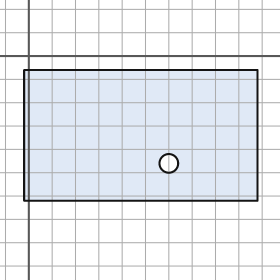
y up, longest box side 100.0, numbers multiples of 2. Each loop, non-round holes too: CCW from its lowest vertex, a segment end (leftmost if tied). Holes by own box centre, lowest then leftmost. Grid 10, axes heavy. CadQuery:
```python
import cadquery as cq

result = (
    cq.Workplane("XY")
    .moveTo(-2.0, -62.0)
    .lineTo(98.0, -62.0)
    .lineTo(98.0, -6.0)
    .lineTo(-2.0, -6.0)
    .close()
    .moveTo(60.0, -46.0)
    .circle(4.0)
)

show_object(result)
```